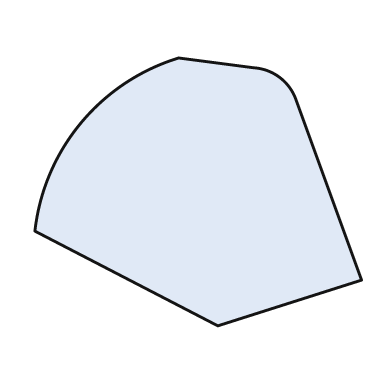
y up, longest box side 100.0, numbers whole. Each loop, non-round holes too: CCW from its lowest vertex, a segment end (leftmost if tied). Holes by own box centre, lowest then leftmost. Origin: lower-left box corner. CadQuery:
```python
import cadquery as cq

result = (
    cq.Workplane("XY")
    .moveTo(56.0, 0.0)
    .lineTo(100.0, 14.0)
    .lineTo(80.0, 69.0)
    .threePointArc((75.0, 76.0), (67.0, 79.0))
    .lineTo(44.0, 82.0)
    .threePointArc((14.0, 62.0), (0.0, 29.0))
    .close()
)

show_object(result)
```